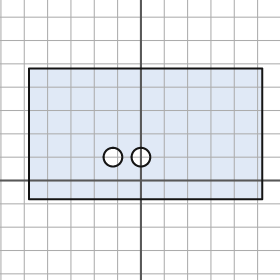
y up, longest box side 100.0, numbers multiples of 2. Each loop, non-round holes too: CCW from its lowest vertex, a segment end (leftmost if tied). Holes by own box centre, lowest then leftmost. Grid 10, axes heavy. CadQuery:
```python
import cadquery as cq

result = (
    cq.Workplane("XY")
    .moveTo(-48.0, -8.0)
    .lineTo(52.0, -8.0)
    .lineTo(52.0, 48.0)
    .lineTo(-48.0, 48.0)
    .close()
    .moveTo(-12.0, 10.0)
    .circle(4.0)
    .moveTo(0.0, 10.0)
    .circle(4.0)
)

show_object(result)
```